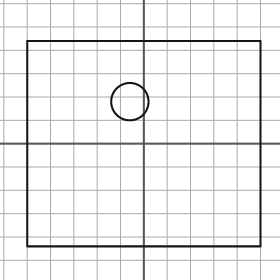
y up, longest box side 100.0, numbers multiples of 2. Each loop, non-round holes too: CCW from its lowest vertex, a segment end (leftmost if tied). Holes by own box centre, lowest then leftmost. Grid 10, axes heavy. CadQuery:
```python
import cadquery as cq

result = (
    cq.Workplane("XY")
    .moveTo(-50.0, -44.0)
    .lineTo(50.0, -44.0)
    .lineTo(50.0, 44.0)
    .lineTo(-50.0, 44.0)
    .close()
    .moveTo(-6.0, 18.0)
    .circle(8.0)
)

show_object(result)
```